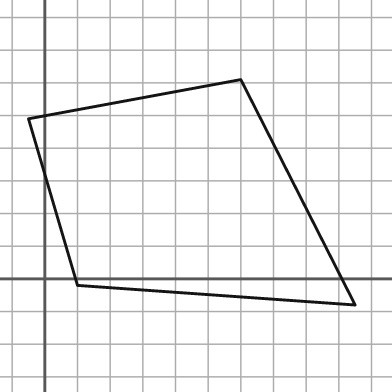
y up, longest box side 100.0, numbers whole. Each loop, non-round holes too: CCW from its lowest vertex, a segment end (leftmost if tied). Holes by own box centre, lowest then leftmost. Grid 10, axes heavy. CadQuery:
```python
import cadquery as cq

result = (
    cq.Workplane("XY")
    .moveTo(95.0, -8.0)
    .lineTo(60.0, 61.0)
    .lineTo(-5.0, 49.0)
    .lineTo(10.0, -2.0)
    .close()
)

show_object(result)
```